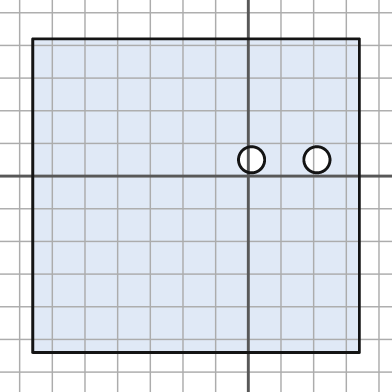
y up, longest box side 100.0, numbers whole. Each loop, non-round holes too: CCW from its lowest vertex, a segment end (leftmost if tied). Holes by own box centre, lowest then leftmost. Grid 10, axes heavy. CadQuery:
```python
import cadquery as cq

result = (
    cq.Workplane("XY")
    .moveTo(-66.0, -54.0)
    .lineTo(34.0, -54.0)
    .lineTo(34.0, 42.0)
    .lineTo(-66.0, 42.0)
    .close()
    .moveTo(1.0, 5.0)
    .circle(4.0)
    .moveTo(21.0, 5.0)
    .circle(4.0)
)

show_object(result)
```